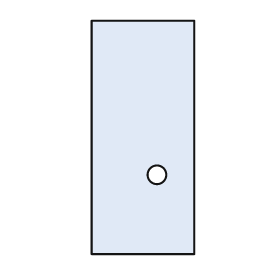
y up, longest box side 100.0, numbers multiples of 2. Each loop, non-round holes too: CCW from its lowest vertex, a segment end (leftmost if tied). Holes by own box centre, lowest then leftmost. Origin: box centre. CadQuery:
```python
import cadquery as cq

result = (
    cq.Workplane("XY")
    .moveTo(-22.0, -50.0)
    .lineTo(22.0, -50.0)
    .lineTo(22.0, 50.0)
    .lineTo(-22.0, 50.0)
    .close()
    .moveTo(6.0, -16.0)
    .circle(4.0)
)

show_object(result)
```